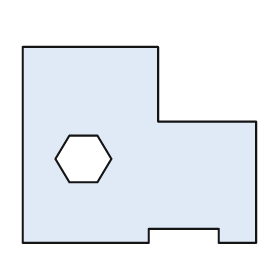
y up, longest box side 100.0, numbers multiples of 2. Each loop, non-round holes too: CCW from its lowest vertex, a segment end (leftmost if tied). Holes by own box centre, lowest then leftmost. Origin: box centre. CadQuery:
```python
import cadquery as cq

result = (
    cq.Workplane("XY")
    .moveTo(-50.0, -42.0)
    .lineTo(4.0, -42.0)
    .lineTo(4.0, -36.0)
    .lineTo(34.0, -36.0)
    .lineTo(34.0, -42.0)
    .lineTo(50.0, -42.0)
    .lineTo(50.0, 10.0)
    .lineTo(8.0, 10.0)
    .lineTo(8.0, 42.0)
    .lineTo(-50.0, 42.0)
    .close()
    .moveTo(-30.0, -16.0)
    .lineTo(-18.0, -16.0)
    .lineTo(-12.0, -6.0)
    .lineTo(-18.0, 4.0)
    .lineTo(-30.0, 4.0)
    .lineTo(-36.0, -6.0)
    .close()
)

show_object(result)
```